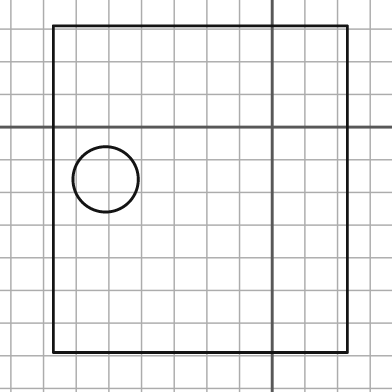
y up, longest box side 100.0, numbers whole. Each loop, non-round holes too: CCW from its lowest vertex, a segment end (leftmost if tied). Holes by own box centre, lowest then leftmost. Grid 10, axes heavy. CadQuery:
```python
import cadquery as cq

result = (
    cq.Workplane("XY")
    .moveTo(-67.0, -69.0)
    .lineTo(23.0, -69.0)
    .lineTo(23.0, 31.0)
    .lineTo(-67.0, 31.0)
    .close()
    .moveTo(-51.0, -16.0)
    .circle(10.0)
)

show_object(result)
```